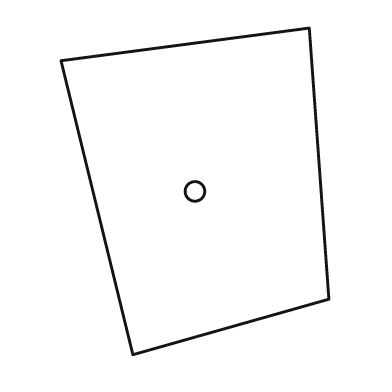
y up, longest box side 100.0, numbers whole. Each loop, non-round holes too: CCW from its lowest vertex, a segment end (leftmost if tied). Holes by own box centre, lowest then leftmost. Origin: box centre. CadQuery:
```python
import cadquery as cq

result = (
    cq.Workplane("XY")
    .moveTo(-19.0, -50.0)
    .lineTo(41.0, -33.0)
    .lineTo(35.0, 50.0)
    .lineTo(-41.0, 40.0)
    .close()
    .moveTo(0.0, 0.0)
    .circle(3.0)
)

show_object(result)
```